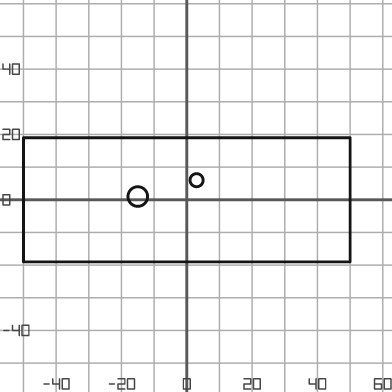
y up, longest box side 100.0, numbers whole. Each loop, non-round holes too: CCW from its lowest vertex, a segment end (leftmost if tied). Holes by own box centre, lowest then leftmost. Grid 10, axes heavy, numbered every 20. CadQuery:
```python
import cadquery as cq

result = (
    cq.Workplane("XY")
    .moveTo(-50.0, -19.0)
    .lineTo(50.0, -19.0)
    .lineTo(50.0, 19.0)
    .lineTo(-50.0, 19.0)
    .close()
    .moveTo(-15.0, 1.0)
    .circle(3.0)
    .moveTo(3.0, 6.0)
    .circle(2.0)
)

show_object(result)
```